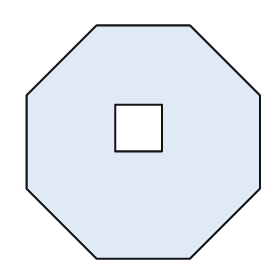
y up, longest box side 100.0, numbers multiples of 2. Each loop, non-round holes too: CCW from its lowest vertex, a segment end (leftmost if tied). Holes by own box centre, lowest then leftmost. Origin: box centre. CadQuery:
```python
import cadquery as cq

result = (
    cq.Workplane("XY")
    .moveTo(-20.0, -50.0)
    .lineTo(20.0, -50.0)
    .lineTo(50.0, -20.0)
    .lineTo(50.0, 20.0)
    .lineTo(20.0, 50.0)
    .lineTo(-20.0, 50.0)
    .lineTo(-50.0, 20.0)
    .lineTo(-50.0, -20.0)
    .close()
    .moveTo(-12.0, -4.0)
    .lineTo(8.0, -4.0)
    .lineTo(8.0, 16.0)
    .lineTo(-12.0, 16.0)
    .close()
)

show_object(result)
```